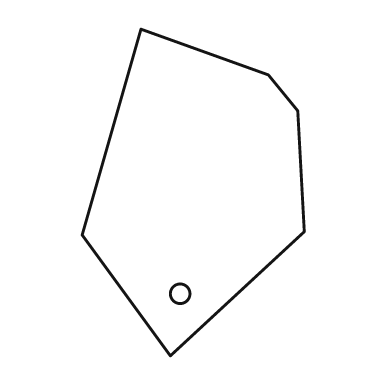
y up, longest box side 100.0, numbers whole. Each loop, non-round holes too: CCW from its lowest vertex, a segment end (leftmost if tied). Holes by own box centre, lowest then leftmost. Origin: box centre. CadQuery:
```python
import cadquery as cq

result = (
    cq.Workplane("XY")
    .moveTo(-7.0, -50.0)
    .lineTo(34.0, -12.0)
    .lineTo(32.0, 25.0)
    .lineTo(23.0, 36.0)
    .lineTo(-16.0, 50.0)
    .lineTo(-34.0, -13.0)
    .close()
    .moveTo(-4.0, -31.0)
    .circle(3.0)
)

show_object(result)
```